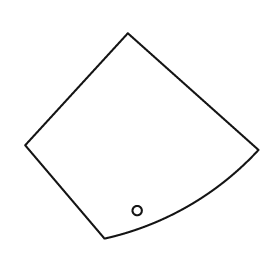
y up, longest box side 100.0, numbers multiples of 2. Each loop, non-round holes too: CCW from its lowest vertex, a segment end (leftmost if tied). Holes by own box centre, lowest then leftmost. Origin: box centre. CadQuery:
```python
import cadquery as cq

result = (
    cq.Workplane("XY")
    .moveTo(-16.0, -44.0)
    .threePointArc((20.0, -30.0), (50.0, -6.0))
    .lineTo(-6.0, 44.0)
    .lineTo(-50.0, -4.0)
    .close()
    .moveTo(-2.0, -32.0)
    .circle(2.0)
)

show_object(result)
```